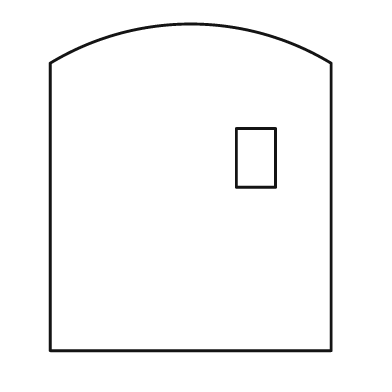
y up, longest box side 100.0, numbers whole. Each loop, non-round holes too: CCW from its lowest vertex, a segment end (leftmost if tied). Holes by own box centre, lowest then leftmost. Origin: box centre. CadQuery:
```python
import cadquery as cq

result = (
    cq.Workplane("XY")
    .moveTo(-43.0, -50.0)
    .lineTo(43.0, -50.0)
    .lineTo(43.0, 38.0)
    .threePointArc((0.0, 50.0), (-43.0, 38.0))
    .close()
    .moveTo(14.0, 0.0)
    .lineTo(26.0, 0.0)
    .lineTo(26.0, 18.0)
    .lineTo(14.0, 18.0)
    .close()
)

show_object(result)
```